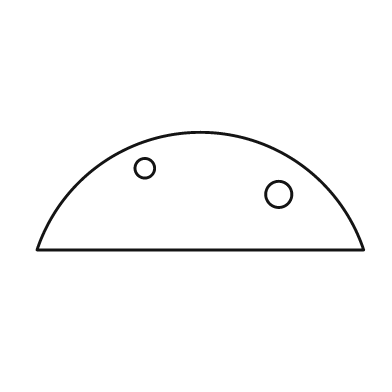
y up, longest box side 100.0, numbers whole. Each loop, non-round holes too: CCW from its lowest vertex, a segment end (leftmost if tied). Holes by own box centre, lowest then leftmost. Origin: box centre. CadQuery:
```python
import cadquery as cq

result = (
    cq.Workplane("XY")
    .moveTo(-50.0, -18.0)
    .lineTo(50.0, -18.0)
    .threePointArc((0.0, 18.0), (-50.0, -18.0))
    .close()
    .moveTo(24.0, -1.0)
    .circle(4.0)
    .moveTo(-17.0, 7.0)
    .circle(3.0)
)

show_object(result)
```